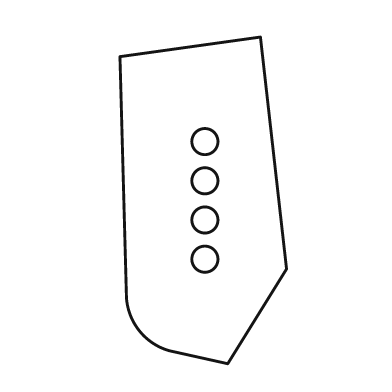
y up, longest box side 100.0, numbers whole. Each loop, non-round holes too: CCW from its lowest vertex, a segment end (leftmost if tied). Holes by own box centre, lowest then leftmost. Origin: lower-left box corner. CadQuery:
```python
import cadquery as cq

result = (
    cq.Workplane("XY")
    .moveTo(33.0, 0.0)
    .lineTo(51.0, 29.0)
    .lineTo(43.0, 100.0)
    .lineTo(0.0, 94.0)
    .lineTo(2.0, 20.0)
    .threePointArc((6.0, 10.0), (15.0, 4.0))
    .close()
    .moveTo(26.0, 32.0)
    .circle(4.0)
    .moveTo(26.0, 44.0)
    .circle(4.0)
    .moveTo(26.0, 56.0)
    .circle(4.0)
    .moveTo(26.0, 68.0)
    .circle(4.0)
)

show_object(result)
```